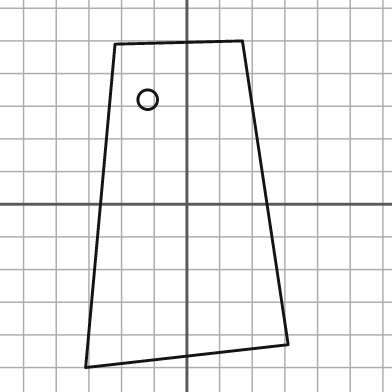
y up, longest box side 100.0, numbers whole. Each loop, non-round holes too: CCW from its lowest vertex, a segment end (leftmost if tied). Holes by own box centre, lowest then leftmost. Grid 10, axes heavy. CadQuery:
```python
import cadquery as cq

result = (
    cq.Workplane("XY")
    .moveTo(-31.0, -50.0)
    .lineTo(31.0, -43.0)
    .lineTo(17.0, 50.0)
    .lineTo(-22.0, 49.0)
    .close()
    .moveTo(-12.0, 32.0)
    .circle(3.0)
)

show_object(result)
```